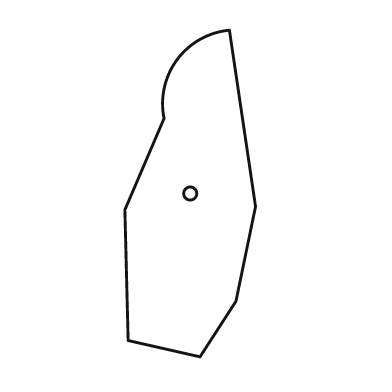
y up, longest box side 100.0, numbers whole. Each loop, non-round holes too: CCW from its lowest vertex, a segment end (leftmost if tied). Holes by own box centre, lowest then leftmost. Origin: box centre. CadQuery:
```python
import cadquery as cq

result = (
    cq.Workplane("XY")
    .moveTo(3.0, -50.0)
    .lineTo(14.0, -33.0)
    .lineTo(20.0, -4.0)
    .lineTo(12.0, 50.0)
    .threePointArc((-4.0, 41.0), (-8.0, 23.0))
    .lineTo(-20.0, -5.0)
    .lineTo(-19.0, -45.0)
    .close()
    .moveTo(0.0, 0.0)
    .circle(2.0)
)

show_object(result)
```